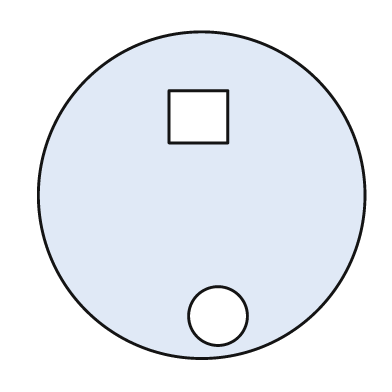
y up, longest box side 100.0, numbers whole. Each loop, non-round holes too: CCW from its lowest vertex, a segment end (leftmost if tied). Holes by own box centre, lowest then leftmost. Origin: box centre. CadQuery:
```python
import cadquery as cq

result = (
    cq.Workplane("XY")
    .moveTo(0.0, 0.0)
    .circle(50.0)
    .moveTo(5.0, -37.0)
    .circle(9.0)
    .moveTo(-10.0, 16.0)
    .lineTo(8.0, 16.0)
    .lineTo(8.0, 32.0)
    .lineTo(-10.0, 32.0)
    .close()
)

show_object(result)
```